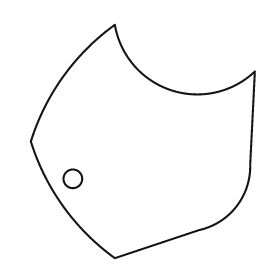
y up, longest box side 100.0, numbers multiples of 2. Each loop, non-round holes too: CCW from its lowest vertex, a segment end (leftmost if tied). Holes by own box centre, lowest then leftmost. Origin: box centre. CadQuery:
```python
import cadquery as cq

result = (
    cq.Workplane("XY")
    .moveTo(-12.0, -50.0)
    .lineTo(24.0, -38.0)
    .threePointArc((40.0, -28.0), (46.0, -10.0))
    .lineTo(48.0, 30.0)
    .threePointArc((12.0, 22.0), (-12.0, 50.0))
    .threePointArc((-34.0, 28.0), (-48.0, 0.0))
    .threePointArc((-34.0, -28.0), (-12.0, -50.0))
    .close()
    .moveTo(-30.0, -16.0)
    .circle(4.0)
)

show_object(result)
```